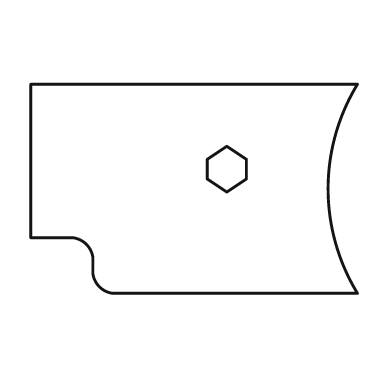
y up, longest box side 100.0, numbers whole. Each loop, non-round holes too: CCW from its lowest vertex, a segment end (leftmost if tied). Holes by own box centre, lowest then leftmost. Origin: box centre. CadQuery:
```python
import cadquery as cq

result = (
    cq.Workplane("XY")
    .moveTo(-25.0, -32.0)
    .lineTo(50.0, -32.0)
    .threePointArc((41.0, 0.0), (50.0, 32.0))
    .lineTo(-50.0, 32.0)
    .lineTo(-50.0, -15.0)
    .lineTo(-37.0, -15.0)
    .threePointArc((-33.0, -17.0), (-31.0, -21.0))
    .lineTo(-31.0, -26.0)
    .threePointArc((-29.0, -30.0), (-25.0, -32.0))
    .close()
    .moveTo(10.0, -1.0)
    .lineTo(16.0, 3.0)
    .lineTo(16.0, 9.0)
    .lineTo(10.0, 13.0)
    .lineTo(4.0, 9.0)
    .lineTo(4.0, 3.0)
    .close()
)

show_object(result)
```